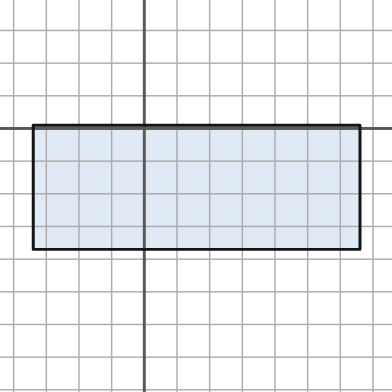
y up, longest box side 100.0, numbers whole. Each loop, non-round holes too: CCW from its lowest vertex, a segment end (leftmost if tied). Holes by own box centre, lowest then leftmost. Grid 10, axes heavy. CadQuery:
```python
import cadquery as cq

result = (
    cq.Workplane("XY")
    .moveTo(-34.0, -37.0)
    .lineTo(66.0, -37.0)
    .lineTo(66.0, 1.0)
    .lineTo(-34.0, 1.0)
    .close()
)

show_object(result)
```